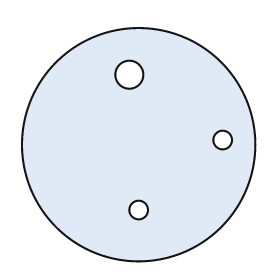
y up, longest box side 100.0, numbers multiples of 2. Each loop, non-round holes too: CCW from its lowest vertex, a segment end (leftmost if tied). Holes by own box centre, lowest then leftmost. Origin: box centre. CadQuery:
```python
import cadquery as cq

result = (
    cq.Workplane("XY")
    .moveTo(0.0, 0.0)
    .circle(50.0)
    .moveTo(0.0, -28.0)
    .circle(4.0)
    .moveTo(36.0, 2.0)
    .circle(4.0)
    .moveTo(-4.0, 30.0)
    .circle(6.0)
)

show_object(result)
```